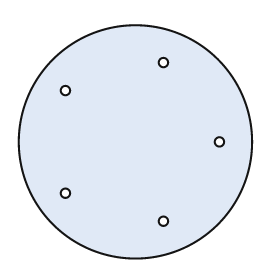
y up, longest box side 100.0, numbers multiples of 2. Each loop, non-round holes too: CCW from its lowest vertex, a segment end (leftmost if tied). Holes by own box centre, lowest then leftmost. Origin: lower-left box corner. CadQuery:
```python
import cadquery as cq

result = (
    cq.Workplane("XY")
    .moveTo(50.0, 50.0)
    .circle(50.0)
    .moveTo(62.0, 16.0)
    .circle(2.0)
    .moveTo(20.0, 28.0)
    .circle(2.0)
    .moveTo(86.0, 50.0)
    .circle(2.0)
    .moveTo(20.0, 72.0)
    .circle(2.0)
    .moveTo(62.0, 84.0)
    .circle(2.0)
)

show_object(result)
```